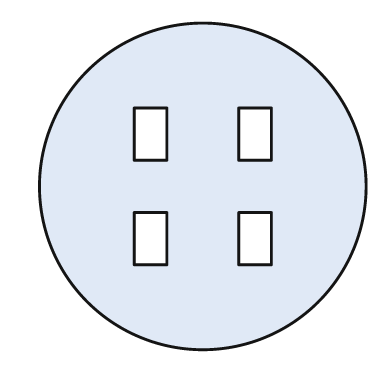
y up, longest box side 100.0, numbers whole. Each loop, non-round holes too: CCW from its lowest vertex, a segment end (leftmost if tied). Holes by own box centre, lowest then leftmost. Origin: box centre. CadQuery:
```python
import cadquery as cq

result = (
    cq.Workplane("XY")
    .moveTo(0.0, 0.0)
    .circle(50.0)
    .moveTo(-21.0, -24.0)
    .lineTo(-11.0, -24.0)
    .lineTo(-11.0, -8.0)
    .lineTo(-21.0, -8.0)
    .close()
    .moveTo(11.0, -24.0)
    .lineTo(21.0, -24.0)
    .lineTo(21.0, -8.0)
    .lineTo(11.0, -8.0)
    .close()
    .moveTo(-21.0, 8.0)
    .lineTo(-11.0, 8.0)
    .lineTo(-11.0, 24.0)
    .lineTo(-21.0, 24.0)
    .close()
    .moveTo(11.0, 8.0)
    .lineTo(21.0, 8.0)
    .lineTo(21.0, 24.0)
    .lineTo(11.0, 24.0)
    .close()
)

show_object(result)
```